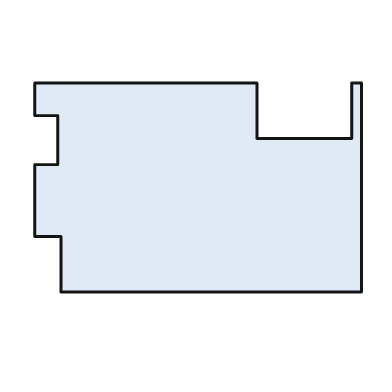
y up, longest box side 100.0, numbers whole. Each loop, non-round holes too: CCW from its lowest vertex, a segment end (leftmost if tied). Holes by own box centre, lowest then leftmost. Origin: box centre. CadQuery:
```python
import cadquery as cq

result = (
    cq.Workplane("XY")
    .moveTo(-42.0, -32.0)
    .lineTo(50.0, -32.0)
    .lineTo(50.0, 32.0)
    .lineTo(47.0, 32.0)
    .lineTo(47.0, 15.0)
    .lineTo(18.0, 15.0)
    .lineTo(18.0, 32.0)
    .lineTo(-50.0, 32.0)
    .lineTo(-50.0, 22.0)
    .lineTo(-43.0, 22.0)
    .lineTo(-43.0, 7.0)
    .lineTo(-50.0, 7.0)
    .lineTo(-50.0, -15.0)
    .lineTo(-42.0, -15.0)
    .close()
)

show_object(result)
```